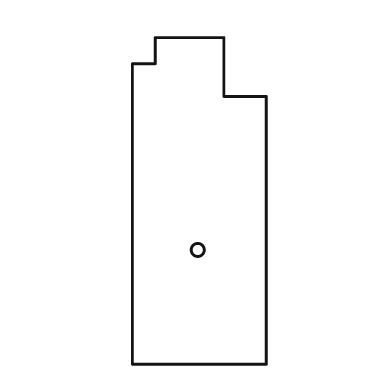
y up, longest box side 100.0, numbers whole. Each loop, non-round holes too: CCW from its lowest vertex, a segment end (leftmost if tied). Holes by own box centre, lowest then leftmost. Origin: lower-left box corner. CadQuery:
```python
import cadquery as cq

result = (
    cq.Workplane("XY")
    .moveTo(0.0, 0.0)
    .lineTo(41.0, 0.0)
    .lineTo(41.0, 82.0)
    .lineTo(28.0, 82.0)
    .lineTo(28.0, 100.0)
    .lineTo(7.0, 100.0)
    .lineTo(7.0, 92.0)
    .lineTo(0.0, 92.0)
    .close()
    .moveTo(20.0, 35.0)
    .circle(2.0)
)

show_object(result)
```